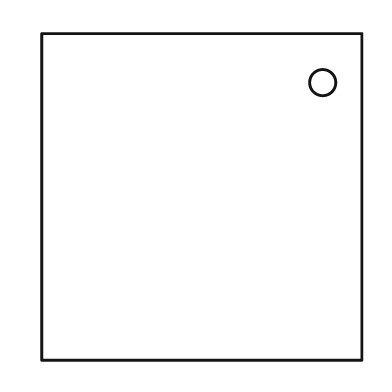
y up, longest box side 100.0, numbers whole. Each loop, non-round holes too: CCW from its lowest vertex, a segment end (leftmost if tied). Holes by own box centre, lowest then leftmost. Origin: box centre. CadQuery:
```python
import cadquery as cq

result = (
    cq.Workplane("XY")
    .moveTo(-49.0, -50.0)
    .lineTo(49.0, -50.0)
    .lineTo(49.0, 50.0)
    .lineTo(-49.0, 50.0)
    .close()
    .moveTo(37.0, 35.0)
    .circle(4.0)
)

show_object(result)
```